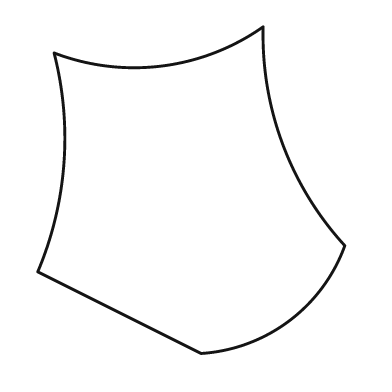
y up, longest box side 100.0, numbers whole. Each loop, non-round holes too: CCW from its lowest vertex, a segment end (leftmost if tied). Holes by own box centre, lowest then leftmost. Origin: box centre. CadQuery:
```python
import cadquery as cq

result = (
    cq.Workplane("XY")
    .moveTo(3.0, -50.0)
    .threePointArc((30.0, -40.0), (47.0, -17.0))
    .threePointArc((28.0, 14.0), (22.0, 50.0))
    .threePointArc((-9.0, 38.0), (-42.0, 42.0))
    .threePointArc((-39.0, 8.0), (-47.0, -25.0))
    .close()
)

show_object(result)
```